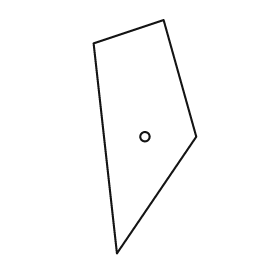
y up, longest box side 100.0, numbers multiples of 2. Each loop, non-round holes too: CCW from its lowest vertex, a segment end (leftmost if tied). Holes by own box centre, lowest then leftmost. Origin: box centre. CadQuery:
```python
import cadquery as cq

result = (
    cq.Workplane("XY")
    .moveTo(-12.0, -50.0)
    .lineTo(22.0, 0.0)
    .lineTo(8.0, 50.0)
    .lineTo(-22.0, 40.0)
    .close()
    .moveTo(0.0, 0.0)
    .circle(2.0)
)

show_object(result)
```